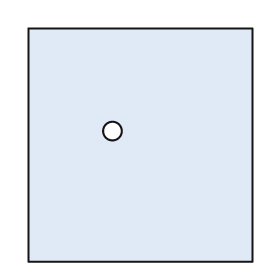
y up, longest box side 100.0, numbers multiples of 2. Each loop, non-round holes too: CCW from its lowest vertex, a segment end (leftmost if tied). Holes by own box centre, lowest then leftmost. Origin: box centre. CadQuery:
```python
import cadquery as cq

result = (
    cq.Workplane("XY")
    .moveTo(-48.0, -50.0)
    .lineTo(48.0, -50.0)
    .lineTo(48.0, 50.0)
    .lineTo(-48.0, 50.0)
    .close()
    .moveTo(-12.0, 6.0)
    .circle(4.0)
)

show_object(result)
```